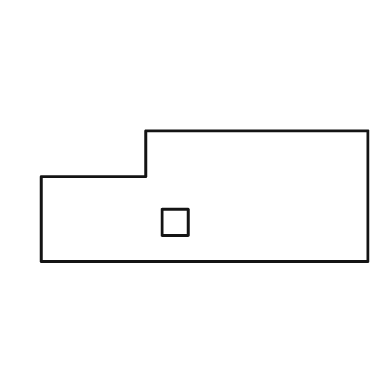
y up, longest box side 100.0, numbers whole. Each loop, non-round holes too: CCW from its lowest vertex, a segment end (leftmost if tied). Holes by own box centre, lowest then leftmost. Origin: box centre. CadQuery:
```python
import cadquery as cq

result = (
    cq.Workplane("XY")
    .moveTo(-50.0, -20.0)
    .lineTo(50.0, -20.0)
    .lineTo(50.0, 20.0)
    .lineTo(-18.0, 20.0)
    .lineTo(-18.0, 6.0)
    .lineTo(-50.0, 6.0)
    .close()
    .moveTo(-13.0, -12.0)
    .lineTo(-5.0, -12.0)
    .lineTo(-5.0, -4.0)
    .lineTo(-13.0, -4.0)
    .close()
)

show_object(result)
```